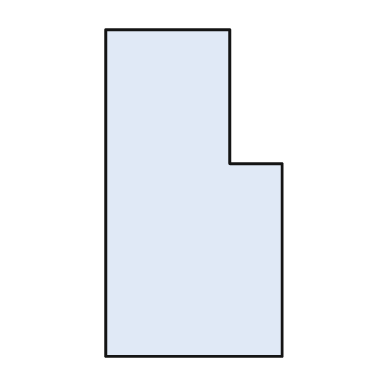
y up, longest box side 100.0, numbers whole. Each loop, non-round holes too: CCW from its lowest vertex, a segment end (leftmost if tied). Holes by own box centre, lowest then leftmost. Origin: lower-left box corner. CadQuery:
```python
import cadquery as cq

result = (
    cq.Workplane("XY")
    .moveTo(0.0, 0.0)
    .lineTo(54.0, 0.0)
    .lineTo(54.0, 59.0)
    .lineTo(38.0, 59.0)
    .lineTo(38.0, 100.0)
    .lineTo(0.0, 100.0)
    .close()
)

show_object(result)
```